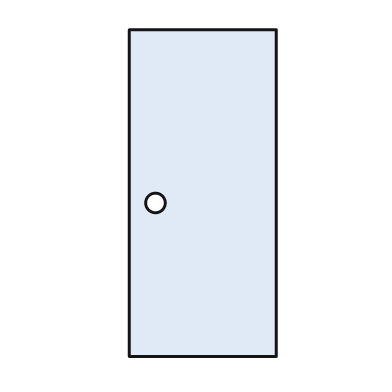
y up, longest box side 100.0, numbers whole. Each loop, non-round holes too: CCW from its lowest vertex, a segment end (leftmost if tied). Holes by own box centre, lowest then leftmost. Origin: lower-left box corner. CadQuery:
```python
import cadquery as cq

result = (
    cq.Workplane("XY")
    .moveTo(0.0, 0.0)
    .lineTo(45.0, 0.0)
    .lineTo(45.0, 100.0)
    .lineTo(0.0, 100.0)
    .close()
    .moveTo(8.0, 47.0)
    .circle(3.0)
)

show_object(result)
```